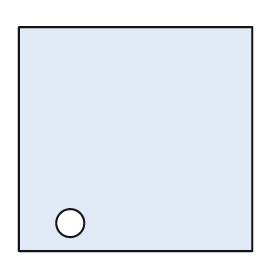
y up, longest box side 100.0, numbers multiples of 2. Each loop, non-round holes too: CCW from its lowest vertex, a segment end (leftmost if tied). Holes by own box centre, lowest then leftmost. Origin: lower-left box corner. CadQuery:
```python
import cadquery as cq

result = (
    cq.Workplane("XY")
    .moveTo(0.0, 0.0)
    .lineTo(100.0, 0.0)
    .lineTo(100.0, 96.0)
    .lineTo(0.0, 96.0)
    .close()
    .moveTo(22.0, 12.0)
    .circle(6.0)
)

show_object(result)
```